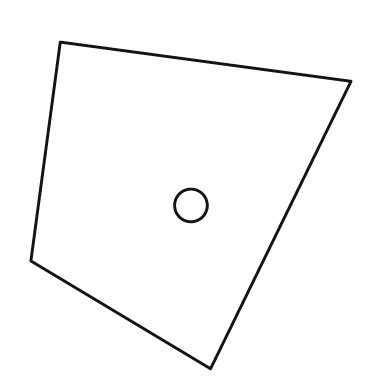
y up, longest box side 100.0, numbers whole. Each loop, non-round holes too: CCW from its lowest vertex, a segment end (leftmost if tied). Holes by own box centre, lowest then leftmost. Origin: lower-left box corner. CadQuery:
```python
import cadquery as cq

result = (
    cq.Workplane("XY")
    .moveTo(55.0, 0.0)
    .lineTo(98.0, 88.0)
    .lineTo(9.0, 100.0)
    .lineTo(0.0, 33.0)
    .close()
    .moveTo(49.0, 50.0)
    .circle(5.0)
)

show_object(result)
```